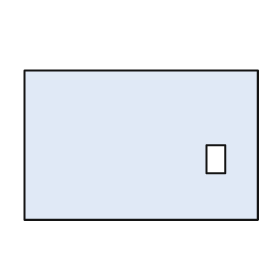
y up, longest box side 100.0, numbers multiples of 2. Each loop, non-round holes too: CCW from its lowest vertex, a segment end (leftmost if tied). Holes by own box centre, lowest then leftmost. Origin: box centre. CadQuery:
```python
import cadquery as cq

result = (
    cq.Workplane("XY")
    .moveTo(-50.0, -32.0)
    .lineTo(50.0, -32.0)
    .lineTo(50.0, 32.0)
    .lineTo(-50.0, 32.0)
    .close()
    .moveTo(28.0, -12.0)
    .lineTo(36.0, -12.0)
    .lineTo(36.0, 0.0)
    .lineTo(28.0, 0.0)
    .close()
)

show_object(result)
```